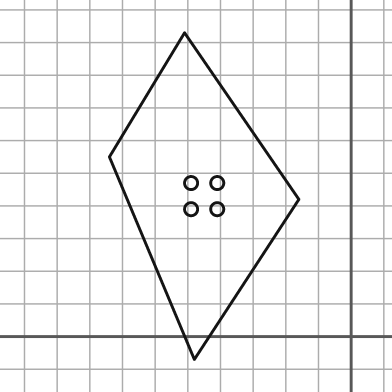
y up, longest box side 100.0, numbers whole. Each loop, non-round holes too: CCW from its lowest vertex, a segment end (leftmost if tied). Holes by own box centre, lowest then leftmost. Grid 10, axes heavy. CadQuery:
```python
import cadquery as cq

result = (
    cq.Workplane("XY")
    .moveTo(-48.0, -7.0)
    .lineTo(-16.0, 42.0)
    .lineTo(-51.0, 93.0)
    .lineTo(-74.0, 55.0)
    .close()
    .moveTo(-49.0, 39.0)
    .circle(2.0)
    .moveTo(-41.0, 39.0)
    .circle(2.0)
    .moveTo(-49.0, 47.0)
    .circle(2.0)
    .moveTo(-41.0, 47.0)
    .circle(2.0)
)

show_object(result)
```